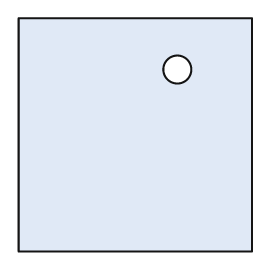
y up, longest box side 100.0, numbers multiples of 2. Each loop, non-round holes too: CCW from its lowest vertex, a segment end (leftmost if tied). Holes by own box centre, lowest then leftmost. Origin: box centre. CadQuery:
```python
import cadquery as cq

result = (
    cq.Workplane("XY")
    .moveTo(-50.0, -50.0)
    .lineTo(50.0, -50.0)
    .lineTo(50.0, 50.0)
    .lineTo(-50.0, 50.0)
    .close()
    .moveTo(18.0, 28.0)
    .circle(6.0)
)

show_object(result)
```